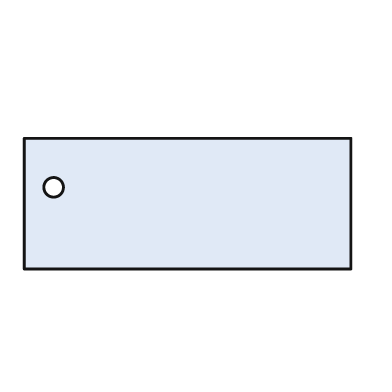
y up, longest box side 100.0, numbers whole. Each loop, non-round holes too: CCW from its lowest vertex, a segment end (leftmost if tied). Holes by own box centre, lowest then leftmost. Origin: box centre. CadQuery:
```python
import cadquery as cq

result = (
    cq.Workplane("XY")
    .moveTo(-50.0, -20.0)
    .lineTo(50.0, -20.0)
    .lineTo(50.0, 20.0)
    .lineTo(-50.0, 20.0)
    .close()
    .moveTo(-41.0, 5.0)
    .circle(3.0)
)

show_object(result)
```